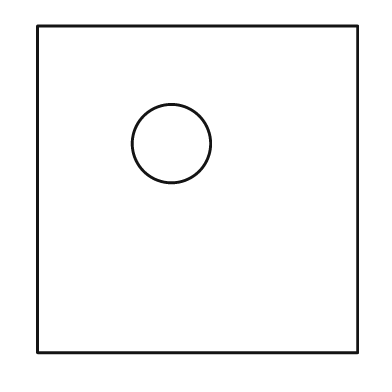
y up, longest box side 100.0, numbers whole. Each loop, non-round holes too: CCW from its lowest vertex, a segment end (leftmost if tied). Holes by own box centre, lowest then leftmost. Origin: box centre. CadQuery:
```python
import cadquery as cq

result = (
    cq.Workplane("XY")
    .moveTo(-49.0, -50.0)
    .lineTo(49.0, -50.0)
    .lineTo(49.0, 50.0)
    .lineTo(-49.0, 50.0)
    .close()
    .moveTo(-8.0, 14.0)
    .circle(12.0)
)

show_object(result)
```